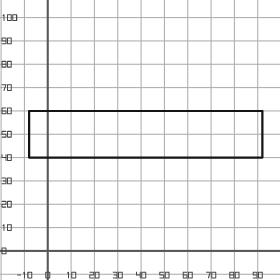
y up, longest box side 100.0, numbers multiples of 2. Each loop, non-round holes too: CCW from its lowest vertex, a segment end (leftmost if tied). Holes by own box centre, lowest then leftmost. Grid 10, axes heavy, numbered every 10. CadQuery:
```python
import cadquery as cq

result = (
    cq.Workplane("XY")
    .moveTo(-8.0, 40.0)
    .lineTo(92.0, 40.0)
    .lineTo(92.0, 60.0)
    .lineTo(-8.0, 60.0)
    .close()
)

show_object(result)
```